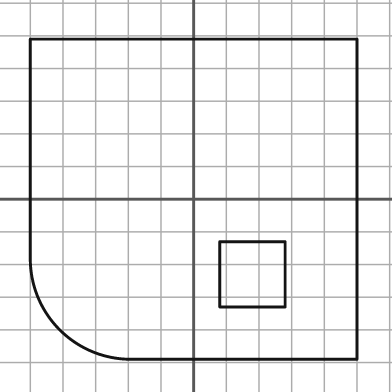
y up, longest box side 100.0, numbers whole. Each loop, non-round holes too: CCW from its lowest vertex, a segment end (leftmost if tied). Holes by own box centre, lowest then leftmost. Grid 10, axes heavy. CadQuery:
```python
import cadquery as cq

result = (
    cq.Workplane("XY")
    .moveTo(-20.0, -49.0)
    .lineTo(50.0, -49.0)
    .lineTo(50.0, 49.0)
    .lineTo(-50.0, 49.0)
    .lineTo(-50.0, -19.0)
    .threePointArc((-41.0, -40.0), (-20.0, -49.0))
    .close()
    .moveTo(8.0, -33.0)
    .lineTo(28.0, -33.0)
    .lineTo(28.0, -13.0)
    .lineTo(8.0, -13.0)
    .close()
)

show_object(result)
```